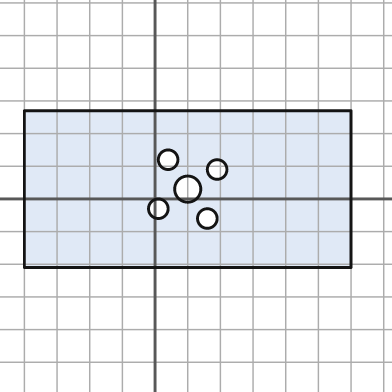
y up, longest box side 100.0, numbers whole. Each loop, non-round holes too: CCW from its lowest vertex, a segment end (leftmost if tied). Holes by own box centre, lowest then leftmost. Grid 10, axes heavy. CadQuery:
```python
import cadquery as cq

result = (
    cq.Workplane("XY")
    .moveTo(-40.0, -21.0)
    .lineTo(60.0, -21.0)
    .lineTo(60.0, 27.0)
    .lineTo(-40.0, 27.0)
    .close()
    .moveTo(16.0, -6.0)
    .circle(3.0)
    .moveTo(1.0, -3.0)
    .circle(3.0)
    .moveTo(10.0, 3.0)
    .circle(4.0)
    .moveTo(19.0, 9.0)
    .circle(3.0)
    .moveTo(4.0, 12.0)
    .circle(3.0)
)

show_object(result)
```